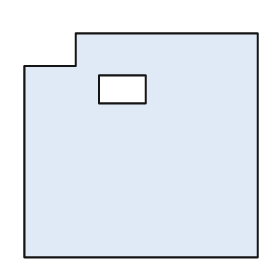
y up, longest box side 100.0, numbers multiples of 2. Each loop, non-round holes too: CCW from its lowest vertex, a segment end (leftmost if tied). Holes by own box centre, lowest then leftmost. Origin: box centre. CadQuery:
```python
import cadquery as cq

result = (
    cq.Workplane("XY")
    .moveTo(-50.0, -48.0)
    .lineTo(50.0, -48.0)
    .lineTo(50.0, 48.0)
    .lineTo(-28.0, 48.0)
    .lineTo(-28.0, 34.0)
    .lineTo(-50.0, 34.0)
    .close()
    .moveTo(-18.0, 18.0)
    .lineTo(2.0, 18.0)
    .lineTo(2.0, 30.0)
    .lineTo(-18.0, 30.0)
    .close()
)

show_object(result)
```